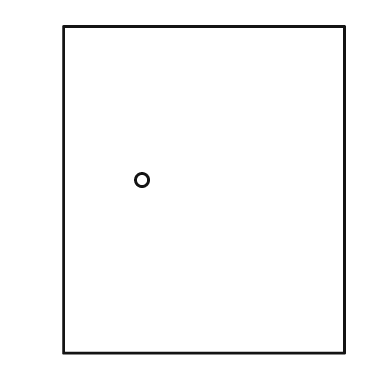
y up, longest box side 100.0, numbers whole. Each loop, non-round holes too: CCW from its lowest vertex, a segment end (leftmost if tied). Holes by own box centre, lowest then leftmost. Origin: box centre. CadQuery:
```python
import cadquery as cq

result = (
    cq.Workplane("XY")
    .moveTo(-43.0, -50.0)
    .lineTo(43.0, -50.0)
    .lineTo(43.0, 50.0)
    .lineTo(-43.0, 50.0)
    .close()
    .moveTo(-19.0, 3.0)
    .circle(2.0)
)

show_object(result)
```